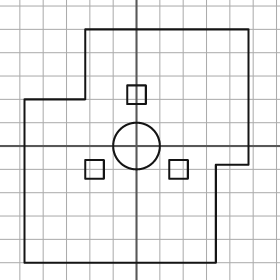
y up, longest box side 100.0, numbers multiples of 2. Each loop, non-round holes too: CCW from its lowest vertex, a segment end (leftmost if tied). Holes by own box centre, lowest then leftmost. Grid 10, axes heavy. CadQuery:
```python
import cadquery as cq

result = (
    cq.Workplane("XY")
    .moveTo(-48.0, -50.0)
    .lineTo(34.0, -50.0)
    .lineTo(34.0, -8.0)
    .lineTo(48.0, -8.0)
    .lineTo(48.0, 50.0)
    .lineTo(-22.0, 50.0)
    .lineTo(-22.0, 20.0)
    .lineTo(-48.0, 20.0)
    .close()
    .moveTo(-22.0, -14.0)
    .lineTo(-14.0, -14.0)
    .lineTo(-14.0, -6.0)
    .lineTo(-22.0, -6.0)
    .close()
    .moveTo(14.0, -14.0)
    .lineTo(22.0, -14.0)
    .lineTo(22.0, -6.0)
    .lineTo(14.0, -6.0)
    .close()
    .moveTo(0.0, 0.0)
    .circle(10.0)
    .moveTo(-4.0, 18.0)
    .lineTo(4.0, 18.0)
    .lineTo(4.0, 26.0)
    .lineTo(-4.0, 26.0)
    .close()
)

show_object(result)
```